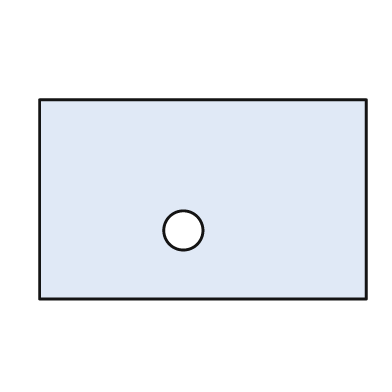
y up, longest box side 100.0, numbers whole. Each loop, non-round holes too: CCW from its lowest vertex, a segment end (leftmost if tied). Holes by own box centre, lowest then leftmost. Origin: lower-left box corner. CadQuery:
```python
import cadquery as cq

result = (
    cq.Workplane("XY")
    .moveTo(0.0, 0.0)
    .lineTo(100.0, 0.0)
    .lineTo(100.0, 61.0)
    .lineTo(0.0, 61.0)
    .close()
    .moveTo(44.0, 21.0)
    .circle(6.0)
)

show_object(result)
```